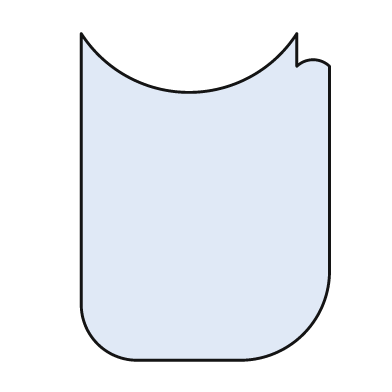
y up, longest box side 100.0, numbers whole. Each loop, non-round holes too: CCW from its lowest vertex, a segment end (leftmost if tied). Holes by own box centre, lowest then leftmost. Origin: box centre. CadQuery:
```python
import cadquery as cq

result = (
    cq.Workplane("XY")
    .moveTo(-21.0, -50.0)
    .lineTo(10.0, -50.0)
    .threePointArc((30.0, -42.0), (38.0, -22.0))
    .lineTo(38.0, 40.0)
    .threePointArc((33.0, 42.0), (28.0, 40.0))
    .lineTo(28.0, 50.0)
    .threePointArc((-5.0, 32.0), (-38.0, 50.0))
    .lineTo(-38.0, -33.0)
    .threePointArc((-33.0, -45.0), (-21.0, -50.0))
    .close()
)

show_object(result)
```